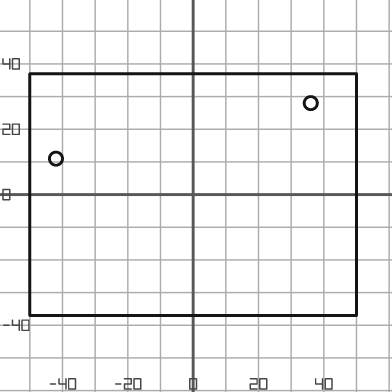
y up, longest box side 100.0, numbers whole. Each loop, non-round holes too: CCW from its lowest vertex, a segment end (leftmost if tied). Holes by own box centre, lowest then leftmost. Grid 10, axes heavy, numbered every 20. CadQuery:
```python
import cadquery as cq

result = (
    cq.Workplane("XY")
    .moveTo(-50.0, -37.0)
    .lineTo(50.0, -37.0)
    .lineTo(50.0, 37.0)
    .lineTo(-50.0, 37.0)
    .close()
    .moveTo(-42.0, 11.0)
    .circle(2.0)
    .moveTo(36.0, 28.0)
    .circle(2.0)
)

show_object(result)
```